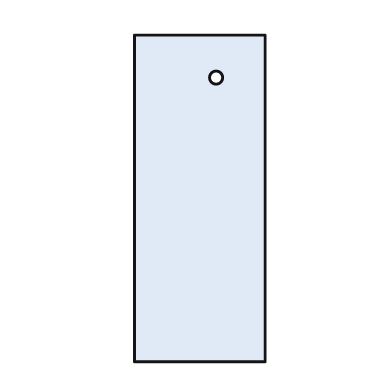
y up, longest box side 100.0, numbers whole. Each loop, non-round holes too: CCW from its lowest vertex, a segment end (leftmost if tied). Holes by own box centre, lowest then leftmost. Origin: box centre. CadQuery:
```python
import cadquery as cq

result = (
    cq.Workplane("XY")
    .moveTo(-20.0, -50.0)
    .lineTo(20.0, -50.0)
    .lineTo(20.0, 50.0)
    .lineTo(-20.0, 50.0)
    .close()
    .moveTo(5.0, 37.0)
    .circle(2.0)
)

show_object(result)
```